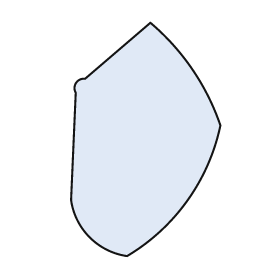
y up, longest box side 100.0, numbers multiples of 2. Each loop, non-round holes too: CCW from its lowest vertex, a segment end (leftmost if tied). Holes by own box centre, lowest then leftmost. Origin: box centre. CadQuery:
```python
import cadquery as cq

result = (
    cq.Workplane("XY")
    .moveTo(-8.0, -50.0)
    .threePointArc((18.0, -26.0), (32.0, 6.0))
    .threePointArc((20.0, 30.0), (2.0, 50.0))
    .lineTo(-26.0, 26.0)
    .threePointArc((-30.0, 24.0), (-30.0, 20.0))
    .lineTo(-32.0, -26.0)
    .threePointArc((-24.0, -42.0), (-8.0, -50.0))
    .close()
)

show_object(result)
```